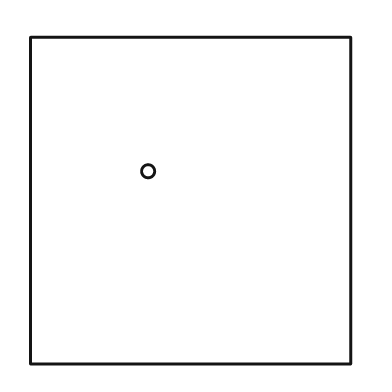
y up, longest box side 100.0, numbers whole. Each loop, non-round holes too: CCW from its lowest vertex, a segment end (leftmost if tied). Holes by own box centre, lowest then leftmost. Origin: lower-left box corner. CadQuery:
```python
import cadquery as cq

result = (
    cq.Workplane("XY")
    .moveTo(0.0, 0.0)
    .lineTo(98.0, 0.0)
    .lineTo(98.0, 100.0)
    .lineTo(0.0, 100.0)
    .close()
    .moveTo(36.0, 59.0)
    .circle(2.0)
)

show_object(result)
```